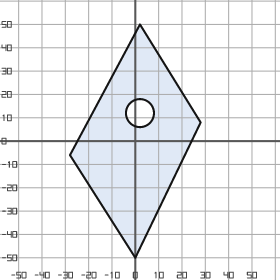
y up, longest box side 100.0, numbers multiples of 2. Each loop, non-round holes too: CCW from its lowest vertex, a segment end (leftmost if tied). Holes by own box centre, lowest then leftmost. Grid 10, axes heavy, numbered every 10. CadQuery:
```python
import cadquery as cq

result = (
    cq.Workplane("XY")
    .moveTo(0.0, -50.0)
    .lineTo(28.0, 8.0)
    .lineTo(2.0, 50.0)
    .lineTo(-28.0, -6.0)
    .close()
    .moveTo(2.0, 12.0)
    .circle(6.0)
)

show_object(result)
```